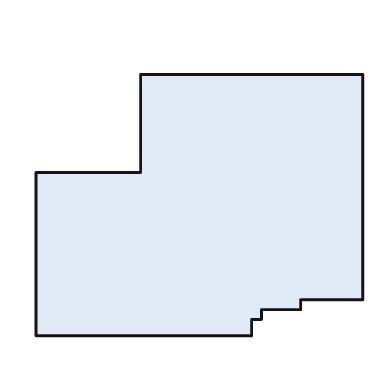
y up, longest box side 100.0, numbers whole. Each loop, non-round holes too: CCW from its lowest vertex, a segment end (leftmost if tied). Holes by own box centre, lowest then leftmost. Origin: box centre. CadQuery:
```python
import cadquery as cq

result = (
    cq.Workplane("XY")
    .moveTo(-50.0, -40.0)
    .lineTo(16.0, -40.0)
    .lineTo(16.0, -35.0)
    .lineTo(19.0, -35.0)
    .lineTo(19.0, -32.0)
    .lineTo(31.0, -32.0)
    .lineTo(31.0, -29.0)
    .lineTo(50.0, -29.0)
    .lineTo(50.0, 40.0)
    .lineTo(-18.0, 40.0)
    .lineTo(-18.0, 10.0)
    .lineTo(-50.0, 10.0)
    .close()
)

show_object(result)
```